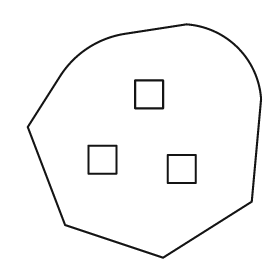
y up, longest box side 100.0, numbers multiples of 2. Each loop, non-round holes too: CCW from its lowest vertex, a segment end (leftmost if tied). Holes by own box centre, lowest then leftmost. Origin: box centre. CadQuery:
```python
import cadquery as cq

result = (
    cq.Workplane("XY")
    .moveTo(8.0, -50.0)
    .lineTo(46.0, -26.0)
    .lineTo(50.0, 18.0)
    .threePointArc((40.0, 40.0), (18.0, 50.0))
    .lineTo(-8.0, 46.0)
    .threePointArc((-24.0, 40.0), (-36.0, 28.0))
    .lineTo(-50.0, 6.0)
    .lineTo(-34.0, -36.0)
    .close()
    .moveTo(10.0, -18.0)
    .lineTo(22.0, -18.0)
    .lineTo(22.0, -6.0)
    .lineTo(10.0, -6.0)
    .close()
    .moveTo(-24.0, -14.0)
    .lineTo(-12.0, -14.0)
    .lineTo(-12.0, -2.0)
    .lineTo(-24.0, -2.0)
    .close()
    .moveTo(-4.0, 14.0)
    .lineTo(8.0, 14.0)
    .lineTo(8.0, 26.0)
    .lineTo(-4.0, 26.0)
    .close()
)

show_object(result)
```